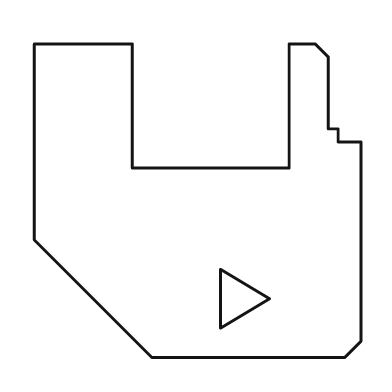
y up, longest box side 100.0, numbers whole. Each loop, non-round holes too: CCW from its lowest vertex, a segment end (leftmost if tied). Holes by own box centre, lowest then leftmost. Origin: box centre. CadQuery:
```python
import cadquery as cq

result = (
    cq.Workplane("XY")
    .moveTo(-14.0, -48.0)
    .lineTo(45.0, -48.0)
    .lineTo(50.0, -43.0)
    .lineTo(50.0, 18.0)
    .lineTo(43.0, 18.0)
    .lineTo(43.0, 22.0)
    .lineTo(40.0, 22.0)
    .lineTo(40.0, 44.0)
    .lineTo(36.0, 48.0)
    .lineTo(28.0, 48.0)
    .lineTo(28.0, 10.0)
    .lineTo(-20.0, 10.0)
    .lineTo(-20.0, 48.0)
    .lineTo(-50.0, 48.0)
    .lineTo(-50.0, -12.0)
    .close()
    .moveTo(7.0, -39.0)
    .lineTo(22.0, -30.0)
    .lineTo(7.0, -21.0)
    .close()
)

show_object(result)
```